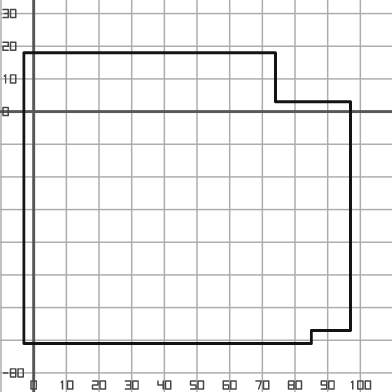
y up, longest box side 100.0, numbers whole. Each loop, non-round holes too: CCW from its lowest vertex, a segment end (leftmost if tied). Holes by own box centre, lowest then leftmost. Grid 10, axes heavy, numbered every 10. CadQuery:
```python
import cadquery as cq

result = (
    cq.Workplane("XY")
    .moveTo(-3.0, -71.0)
    .lineTo(85.0, -71.0)
    .lineTo(85.0, -67.0)
    .lineTo(97.0, -67.0)
    .lineTo(97.0, 3.0)
    .lineTo(74.0, 3.0)
    .lineTo(74.0, 18.0)
    .lineTo(-3.0, 18.0)
    .close()
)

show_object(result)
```